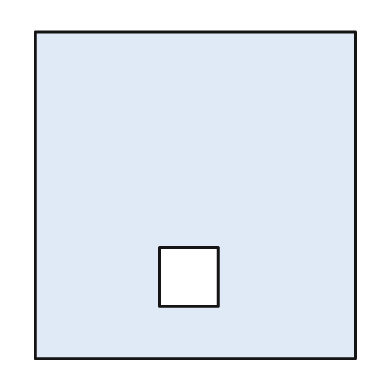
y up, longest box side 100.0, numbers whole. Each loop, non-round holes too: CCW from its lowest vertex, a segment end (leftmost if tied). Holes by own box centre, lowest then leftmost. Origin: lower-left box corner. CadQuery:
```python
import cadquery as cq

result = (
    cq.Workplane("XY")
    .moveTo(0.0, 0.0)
    .lineTo(98.0, 0.0)
    .lineTo(98.0, 100.0)
    .lineTo(0.0, 100.0)
    .close()
    .moveTo(38.0, 16.0)
    .lineTo(56.0, 16.0)
    .lineTo(56.0, 34.0)
    .lineTo(38.0, 34.0)
    .close()
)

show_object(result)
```